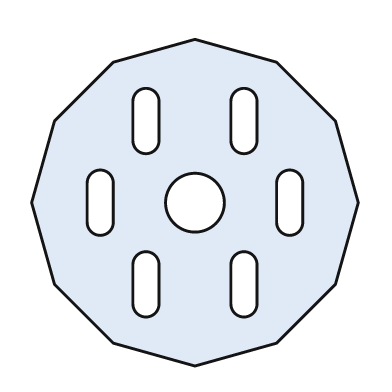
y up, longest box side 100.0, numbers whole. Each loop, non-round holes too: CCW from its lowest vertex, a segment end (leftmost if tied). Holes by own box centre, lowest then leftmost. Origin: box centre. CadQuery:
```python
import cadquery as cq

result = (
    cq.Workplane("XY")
    .moveTo(0.0, -50.0)
    .lineTo(25.0, -43.0)
    .lineTo(43.0, -25.0)
    .lineTo(50.0, 0.0)
    .lineTo(43.0, 25.0)
    .lineTo(25.0, 43.0)
    .lineTo(0.0, 50.0)
    .lineTo(-25.0, 43.0)
    .lineTo(-43.0, 25.0)
    .lineTo(-50.0, 0.0)
    .lineTo(-43.0, -25.0)
    .lineTo(-25.0, -43.0)
    .close()
    .moveTo(-19.0, -31.0)
    .threePointArc((-15.0, -35.0), (-11.0, -31.0))
    .lineTo(-11.0, -19.0)
    .threePointArc((-15.0, -15.0), (-19.0, -19.0))
    .close()
    .moveTo(11.0, -31.0)
    .threePointArc((15.0, -35.0), (19.0, -31.0))
    .lineTo(19.0, -19.0)
    .threePointArc((15.0, -15.0), (11.0, -19.0))
    .close()
    .moveTo(-33.0, -6.0)
    .threePointArc((-29.0, -10.0), (-25.0, -6.0))
    .lineTo(-25.0, 6.0)
    .threePointArc((-29.0, 10.0), (-33.0, 6.0))
    .close()
    .moveTo(0.0, 0.0)
    .circle(9.0)
    .moveTo(25.0, -6.0)
    .threePointArc((29.0, -10.0), (33.0, -6.0))
    .lineTo(33.0, 6.0)
    .threePointArc((29.0, 10.0), (25.0, 6.0))
    .close()
    .moveTo(-19.0, 19.0)
    .threePointArc((-15.0, 15.0), (-11.0, 19.0))
    .lineTo(-11.0, 31.0)
    .threePointArc((-15.0, 35.0), (-19.0, 31.0))
    .close()
    .moveTo(11.0, 19.0)
    .threePointArc((15.0, 15.0), (19.0, 19.0))
    .lineTo(19.0, 31.0)
    .threePointArc((15.0, 35.0), (11.0, 31.0))
    .close()
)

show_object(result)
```